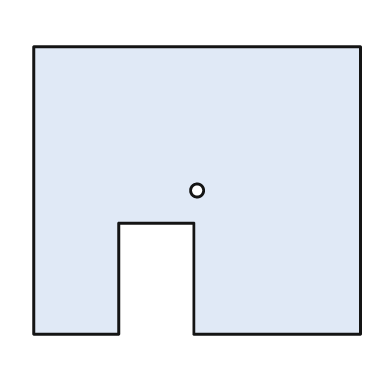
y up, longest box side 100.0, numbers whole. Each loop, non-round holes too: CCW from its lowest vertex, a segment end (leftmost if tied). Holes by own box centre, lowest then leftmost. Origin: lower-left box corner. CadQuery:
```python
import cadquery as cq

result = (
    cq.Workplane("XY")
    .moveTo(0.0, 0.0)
    .lineTo(26.0, 0.0)
    .lineTo(26.0, 34.0)
    .lineTo(49.0, 34.0)
    .lineTo(49.0, 0.0)
    .lineTo(100.0, 0.0)
    .lineTo(100.0, 88.0)
    .lineTo(0.0, 88.0)
    .close()
    .moveTo(50.0, 44.0)
    .circle(2.0)
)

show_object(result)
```